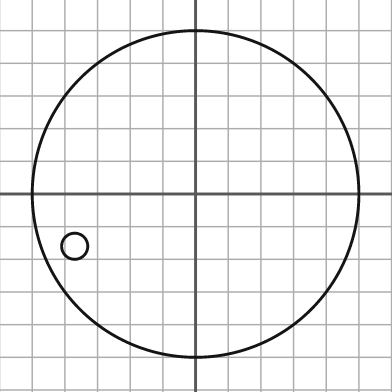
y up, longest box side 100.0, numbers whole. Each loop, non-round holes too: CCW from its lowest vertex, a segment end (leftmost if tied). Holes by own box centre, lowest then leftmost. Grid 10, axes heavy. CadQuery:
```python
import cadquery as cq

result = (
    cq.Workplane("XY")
    .moveTo(0.0, 0.0)
    .circle(50.0)
    .moveTo(-37.0, -16.0)
    .circle(4.0)
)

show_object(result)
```